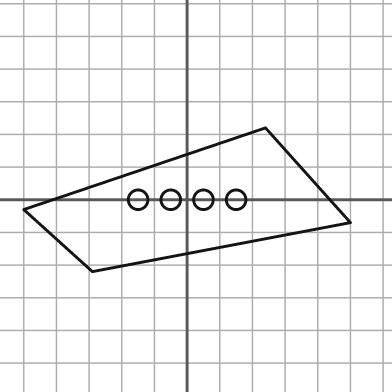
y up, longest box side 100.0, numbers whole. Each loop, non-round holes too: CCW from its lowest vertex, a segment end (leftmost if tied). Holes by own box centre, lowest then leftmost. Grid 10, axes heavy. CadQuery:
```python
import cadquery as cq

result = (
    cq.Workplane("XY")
    .moveTo(-29.0, -22.0)
    .lineTo(50.0, -7.0)
    .lineTo(24.0, 22.0)
    .lineTo(-50.0, -3.0)
    .close()
    .moveTo(-15.0, 0.0)
    .circle(3.0)
    .moveTo(-5.0, 0.0)
    .circle(3.0)
    .moveTo(5.0, 0.0)
    .circle(3.0)
    .moveTo(15.0, 0.0)
    .circle(3.0)
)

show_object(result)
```